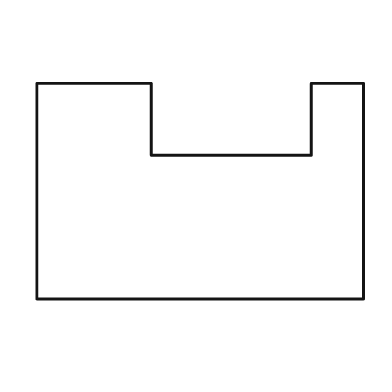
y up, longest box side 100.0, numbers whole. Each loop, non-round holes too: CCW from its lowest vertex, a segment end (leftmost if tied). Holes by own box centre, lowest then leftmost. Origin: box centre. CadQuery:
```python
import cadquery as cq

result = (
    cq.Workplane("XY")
    .moveTo(-50.0, -33.0)
    .lineTo(50.0, -33.0)
    .lineTo(50.0, 33.0)
    .lineTo(34.0, 33.0)
    .lineTo(34.0, 11.0)
    .lineTo(-15.0, 11.0)
    .lineTo(-15.0, 33.0)
    .lineTo(-50.0, 33.0)
    .close()
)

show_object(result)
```